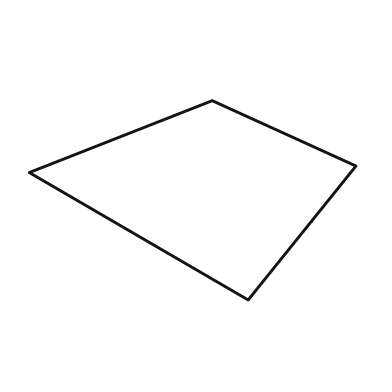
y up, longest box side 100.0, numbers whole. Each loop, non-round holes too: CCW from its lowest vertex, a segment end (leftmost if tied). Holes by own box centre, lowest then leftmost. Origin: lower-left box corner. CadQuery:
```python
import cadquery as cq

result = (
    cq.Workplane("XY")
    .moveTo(67.0, 0.0)
    .lineTo(100.0, 41.0)
    .lineTo(56.0, 61.0)
    .lineTo(0.0, 39.0)
    .close()
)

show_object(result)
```